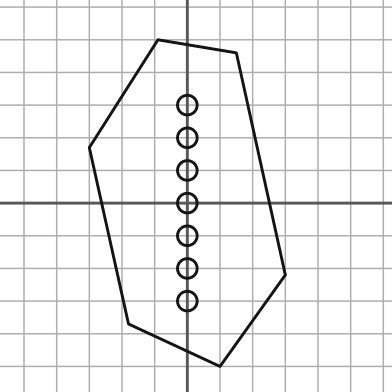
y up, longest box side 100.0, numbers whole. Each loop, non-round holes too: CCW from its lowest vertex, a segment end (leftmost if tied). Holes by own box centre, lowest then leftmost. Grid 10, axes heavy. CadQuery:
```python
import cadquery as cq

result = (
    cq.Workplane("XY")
    .moveTo(10.0, -50.0)
    .lineTo(30.0, -22.0)
    .lineTo(15.0, 46.0)
    .lineTo(-9.0, 50.0)
    .lineTo(-30.0, 17.0)
    .lineTo(-18.0, -37.0)
    .close()
    .moveTo(0.0, -30.0)
    .circle(3.0)
    .moveTo(0.0, -20.0)
    .circle(3.0)
    .moveTo(0.0, -10.0)
    .circle(3.0)
    .moveTo(0.0, 0.0)
    .circle(3.0)
    .moveTo(0.0, 10.0)
    .circle(3.0)
    .moveTo(0.0, 20.0)
    .circle(3.0)
    .moveTo(0.0, 30.0)
    .circle(3.0)
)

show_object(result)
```